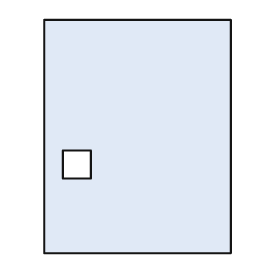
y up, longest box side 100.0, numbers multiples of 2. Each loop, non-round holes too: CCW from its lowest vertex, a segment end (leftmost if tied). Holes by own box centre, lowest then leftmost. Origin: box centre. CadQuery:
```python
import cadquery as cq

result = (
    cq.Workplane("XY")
    .moveTo(-40.0, -50.0)
    .lineTo(40.0, -50.0)
    .lineTo(40.0, 50.0)
    .lineTo(-40.0, 50.0)
    .close()
    .moveTo(-32.0, -18.0)
    .lineTo(-20.0, -18.0)
    .lineTo(-20.0, -6.0)
    .lineTo(-32.0, -6.0)
    .close()
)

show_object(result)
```